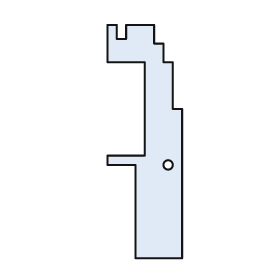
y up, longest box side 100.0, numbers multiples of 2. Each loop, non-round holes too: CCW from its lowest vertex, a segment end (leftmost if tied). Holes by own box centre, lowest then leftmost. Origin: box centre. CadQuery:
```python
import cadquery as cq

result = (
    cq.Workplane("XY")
    .moveTo(-4.0, -50.0)
    .lineTo(16.0, -50.0)
    .lineTo(16.0, 14.0)
    .lineTo(12.0, 14.0)
    .lineTo(12.0, 34.0)
    .lineTo(8.0, 34.0)
    .lineTo(8.0, 42.0)
    .lineTo(4.0, 42.0)
    .lineTo(4.0, 50.0)
    .lineTo(-8.0, 50.0)
    .lineTo(-8.0, 44.0)
    .lineTo(-12.0, 44.0)
    .lineTo(-12.0, 50.0)
    .lineTo(-16.0, 50.0)
    .lineTo(-16.0, 34.0)
    .lineTo(0.0, 34.0)
    .lineTo(0.0, -6.0)
    .lineTo(-16.0, -6.0)
    .lineTo(-16.0, -10.0)
    .lineTo(-4.0, -10.0)
    .close()
    .moveTo(10.0, -10.0)
    .circle(2.0)
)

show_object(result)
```